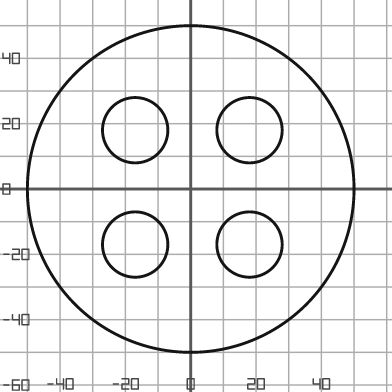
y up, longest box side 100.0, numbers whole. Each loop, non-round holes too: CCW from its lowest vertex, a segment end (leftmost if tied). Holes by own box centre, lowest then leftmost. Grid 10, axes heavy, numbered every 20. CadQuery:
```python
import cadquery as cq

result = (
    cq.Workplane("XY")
    .moveTo(0.0, 0.0)
    .circle(50.0)
    .moveTo(-17.0, -17.0)
    .circle(10.0)
    .moveTo(18.0, -17.0)
    .circle(10.0)
    .moveTo(-17.0, 18.0)
    .circle(10.0)
    .moveTo(18.0, 18.0)
    .circle(10.0)
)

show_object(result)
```